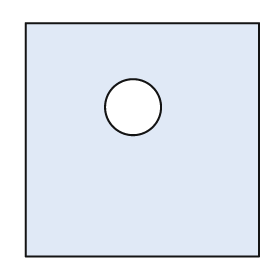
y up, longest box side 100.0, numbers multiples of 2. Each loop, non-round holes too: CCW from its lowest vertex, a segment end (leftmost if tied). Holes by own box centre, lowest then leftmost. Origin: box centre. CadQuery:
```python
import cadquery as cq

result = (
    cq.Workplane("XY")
    .moveTo(-50.0, -50.0)
    .lineTo(50.0, -50.0)
    .lineTo(50.0, 50.0)
    .lineTo(-50.0, 50.0)
    .close()
    .moveTo(-4.0, 14.0)
    .circle(12.0)
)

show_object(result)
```